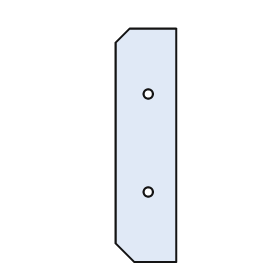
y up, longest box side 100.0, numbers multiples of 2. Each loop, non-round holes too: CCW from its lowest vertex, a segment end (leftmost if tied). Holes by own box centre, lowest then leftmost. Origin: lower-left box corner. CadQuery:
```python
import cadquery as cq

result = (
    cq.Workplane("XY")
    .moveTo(8.0, 0.0)
    .lineTo(26.0, 0.0)
    .lineTo(26.0, 100.0)
    .lineTo(6.0, 100.0)
    .lineTo(0.0, 94.0)
    .lineTo(0.0, 8.0)
    .close()
    .moveTo(14.0, 30.0)
    .circle(2.0)
    .moveTo(14.0, 72.0)
    .circle(2.0)
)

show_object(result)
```